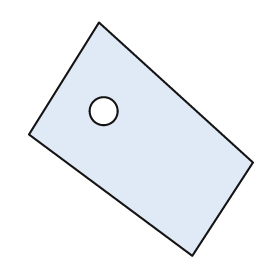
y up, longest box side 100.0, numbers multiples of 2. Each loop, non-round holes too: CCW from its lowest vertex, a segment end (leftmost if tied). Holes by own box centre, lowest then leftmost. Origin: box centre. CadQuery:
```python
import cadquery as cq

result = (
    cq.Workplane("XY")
    .moveTo(22.0, -50.0)
    .lineTo(48.0, -10.0)
    .lineTo(-18.0, 50.0)
    .lineTo(-48.0, 2.0)
    .close()
    .moveTo(-16.0, 12.0)
    .circle(6.0)
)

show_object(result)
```